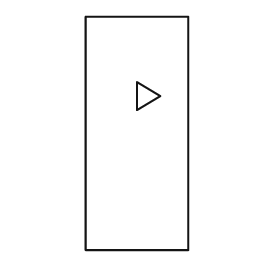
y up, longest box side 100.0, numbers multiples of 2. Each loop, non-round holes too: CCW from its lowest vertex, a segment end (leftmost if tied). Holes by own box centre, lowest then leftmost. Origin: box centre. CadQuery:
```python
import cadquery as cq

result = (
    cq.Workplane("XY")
    .moveTo(-22.0, -50.0)
    .lineTo(22.0, -50.0)
    .lineTo(22.0, 50.0)
    .lineTo(-22.0, 50.0)
    .close()
    .moveTo(0.0, 10.0)
    .lineTo(10.0, 16.0)
    .lineTo(0.0, 22.0)
    .close()
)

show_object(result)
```